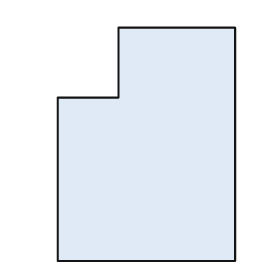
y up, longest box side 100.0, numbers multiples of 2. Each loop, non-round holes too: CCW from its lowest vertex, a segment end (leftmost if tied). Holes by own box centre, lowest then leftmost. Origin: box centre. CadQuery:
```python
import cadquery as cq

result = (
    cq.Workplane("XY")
    .moveTo(-38.0, -50.0)
    .lineTo(38.0, -50.0)
    .lineTo(38.0, 50.0)
    .lineTo(-12.0, 50.0)
    .lineTo(-12.0, 20.0)
    .lineTo(-38.0, 20.0)
    .close()
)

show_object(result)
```